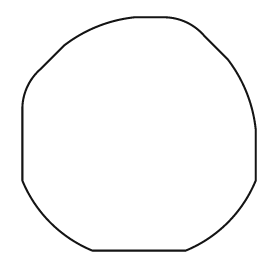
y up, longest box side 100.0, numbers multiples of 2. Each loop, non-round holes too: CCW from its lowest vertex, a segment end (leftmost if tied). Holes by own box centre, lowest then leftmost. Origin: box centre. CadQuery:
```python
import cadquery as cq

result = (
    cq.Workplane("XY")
    .moveTo(-20.0, -50.0)
    .lineTo(20.0, -50.0)
    .threePointArc((38.0, -38.0), (50.0, -20.0))
    .lineTo(50.0, 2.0)
    .threePointArc((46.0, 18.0), (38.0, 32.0))
    .lineTo(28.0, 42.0)
    .threePointArc((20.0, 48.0), (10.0, 50.0))
    .lineTo(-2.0, 50.0)
    .threePointArc((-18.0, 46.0), (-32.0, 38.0))
    .lineTo(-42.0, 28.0)
    .threePointArc((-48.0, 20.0), (-50.0, 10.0))
    .lineTo(-50.0, -20.0)
    .threePointArc((-38.0, -38.0), (-20.0, -50.0))
    .close()
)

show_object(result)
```